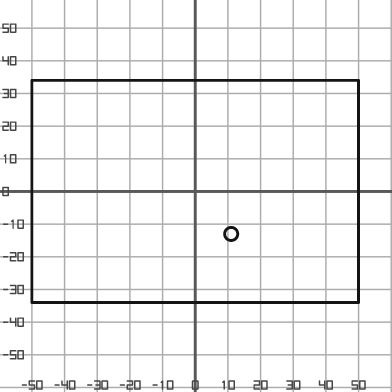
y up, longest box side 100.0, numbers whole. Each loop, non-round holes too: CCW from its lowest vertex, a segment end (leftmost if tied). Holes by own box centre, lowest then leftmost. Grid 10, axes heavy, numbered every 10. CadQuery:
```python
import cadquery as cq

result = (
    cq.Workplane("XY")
    .moveTo(-50.0, -34.0)
    .lineTo(50.0, -34.0)
    .lineTo(50.0, 34.0)
    .lineTo(-50.0, 34.0)
    .close()
    .moveTo(11.0, -13.0)
    .circle(2.0)
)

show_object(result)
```